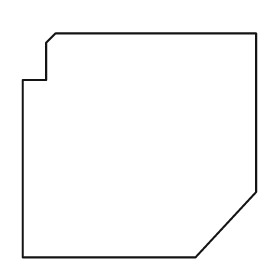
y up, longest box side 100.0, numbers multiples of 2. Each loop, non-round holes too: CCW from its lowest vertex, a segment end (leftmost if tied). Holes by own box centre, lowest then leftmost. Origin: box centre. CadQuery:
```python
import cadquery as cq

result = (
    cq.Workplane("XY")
    .moveTo(-50.0, -48.0)
    .lineTo(24.0, -48.0)
    .lineTo(50.0, -20.0)
    .lineTo(50.0, 48.0)
    .lineTo(-36.0, 48.0)
    .lineTo(-40.0, 44.0)
    .lineTo(-40.0, 28.0)
    .lineTo(-50.0, 28.0)
    .close()
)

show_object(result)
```